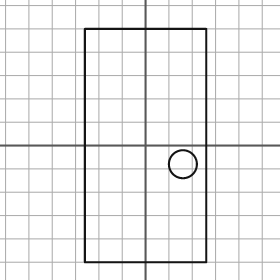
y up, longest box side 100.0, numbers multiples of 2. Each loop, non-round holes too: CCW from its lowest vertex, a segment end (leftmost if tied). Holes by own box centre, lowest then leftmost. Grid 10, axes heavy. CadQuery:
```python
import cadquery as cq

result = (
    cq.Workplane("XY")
    .moveTo(-26.0, -50.0)
    .lineTo(26.0, -50.0)
    .lineTo(26.0, 50.0)
    .lineTo(-26.0, 50.0)
    .close()
    .moveTo(16.0, -8.0)
    .circle(6.0)
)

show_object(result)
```